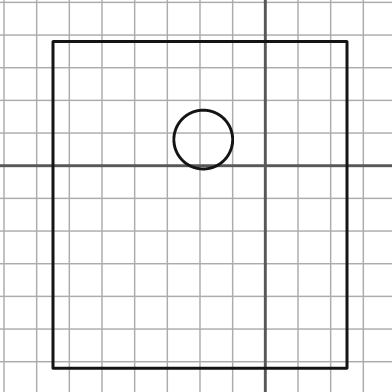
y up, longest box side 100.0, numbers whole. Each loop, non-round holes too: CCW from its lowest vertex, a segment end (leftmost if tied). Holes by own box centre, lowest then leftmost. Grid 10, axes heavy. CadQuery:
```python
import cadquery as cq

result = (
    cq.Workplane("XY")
    .moveTo(-65.0, -62.0)
    .lineTo(25.0, -62.0)
    .lineTo(25.0, 38.0)
    .lineTo(-65.0, 38.0)
    .close()
    .moveTo(-19.0, 8.0)
    .circle(9.0)
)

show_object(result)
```